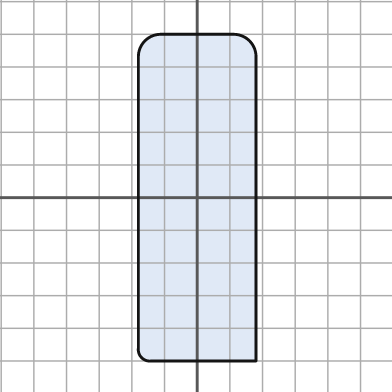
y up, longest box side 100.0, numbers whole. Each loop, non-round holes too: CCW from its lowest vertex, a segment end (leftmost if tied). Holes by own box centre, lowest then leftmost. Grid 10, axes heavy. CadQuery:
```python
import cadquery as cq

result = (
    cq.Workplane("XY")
    .moveTo(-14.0, -50.0)
    .lineTo(18.0, -50.0)
    .lineTo(18.0, 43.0)
    .threePointArc((16.0, 48.0), (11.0, 50.0))
    .lineTo(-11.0, 50.0)
    .threePointArc((-16.0, 48.0), (-18.0, 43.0))
    .lineTo(-18.0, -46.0)
    .threePointArc((-17.0, -49.0), (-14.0, -50.0))
    .close()
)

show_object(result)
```